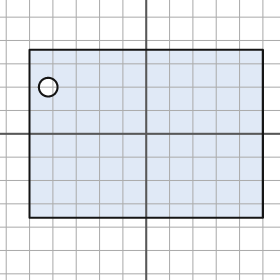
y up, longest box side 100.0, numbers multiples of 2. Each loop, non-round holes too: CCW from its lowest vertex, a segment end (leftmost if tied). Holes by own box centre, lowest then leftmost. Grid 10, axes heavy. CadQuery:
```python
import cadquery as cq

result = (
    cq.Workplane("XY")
    .moveTo(-50.0, -36.0)
    .lineTo(50.0, -36.0)
    .lineTo(50.0, 36.0)
    .lineTo(-50.0, 36.0)
    .close()
    .moveTo(-42.0, 20.0)
    .circle(4.0)
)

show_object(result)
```